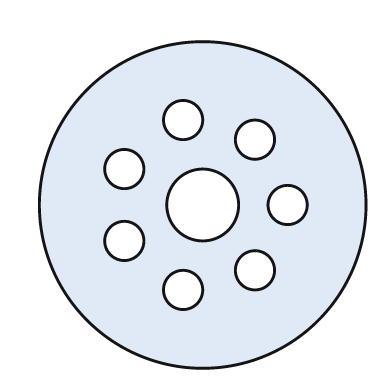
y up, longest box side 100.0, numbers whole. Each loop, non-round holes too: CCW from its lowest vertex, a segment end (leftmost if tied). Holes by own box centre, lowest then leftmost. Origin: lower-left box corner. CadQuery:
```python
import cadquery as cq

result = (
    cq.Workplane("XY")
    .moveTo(50.0, 50.0)
    .circle(50.0)
    .moveTo(44.0, 24.0)
    .circle(6.0)
    .moveTo(66.0, 30.0)
    .circle(6.0)
    .moveTo(26.0, 39.0)
    .circle(6.0)
    .moveTo(50.0, 50.0)
    .circle(11.0)
    .moveTo(76.0, 50.0)
    .circle(6.0)
    .moveTo(26.0, 61.0)
    .circle(6.0)
    .moveTo(66.0, 70.0)
    .circle(6.0)
    .moveTo(44.0, 76.0)
    .circle(6.0)
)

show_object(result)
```